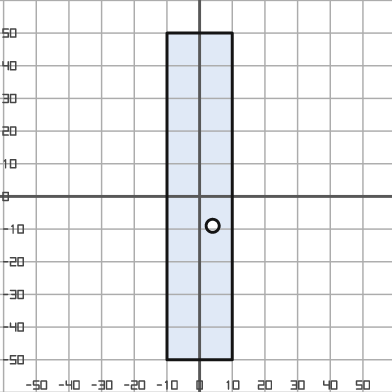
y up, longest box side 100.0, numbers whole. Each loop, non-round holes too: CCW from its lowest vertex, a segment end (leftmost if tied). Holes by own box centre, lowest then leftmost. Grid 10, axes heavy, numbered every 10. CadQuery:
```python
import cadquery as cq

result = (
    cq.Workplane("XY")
    .moveTo(-10.0, -50.0)
    .lineTo(10.0, -50.0)
    .lineTo(10.0, 50.0)
    .lineTo(-10.0, 50.0)
    .close()
    .moveTo(4.0, -9.0)
    .circle(2.0)
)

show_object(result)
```